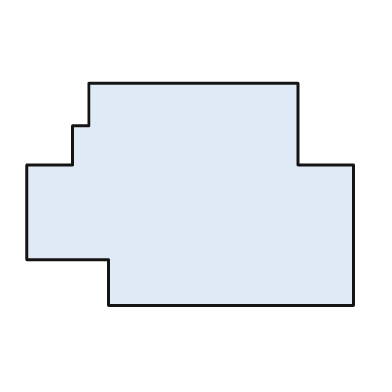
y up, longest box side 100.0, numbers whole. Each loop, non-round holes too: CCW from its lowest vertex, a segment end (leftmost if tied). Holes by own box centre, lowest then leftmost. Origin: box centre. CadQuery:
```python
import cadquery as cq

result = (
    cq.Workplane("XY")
    .moveTo(-25.0, -34.0)
    .lineTo(50.0, -34.0)
    .lineTo(50.0, 9.0)
    .lineTo(33.0, 9.0)
    .lineTo(33.0, 34.0)
    .lineTo(-31.0, 34.0)
    .lineTo(-31.0, 21.0)
    .lineTo(-36.0, 21.0)
    .lineTo(-36.0, 9.0)
    .lineTo(-50.0, 9.0)
    .lineTo(-50.0, -20.0)
    .lineTo(-25.0, -20.0)
    .close()
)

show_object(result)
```